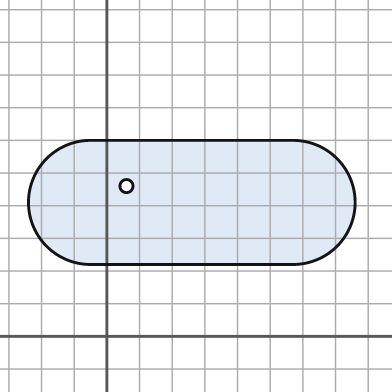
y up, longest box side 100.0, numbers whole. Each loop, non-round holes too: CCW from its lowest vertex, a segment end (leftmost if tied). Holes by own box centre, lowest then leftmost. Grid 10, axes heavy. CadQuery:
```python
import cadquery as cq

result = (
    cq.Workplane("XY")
    .moveTo(-5.0, 22.0)
    .lineTo(57.0, 22.0)
    .threePointArc((76.0, 41.0), (57.0, 60.0))
    .lineTo(-5.0, 60.0)
    .threePointArc((-24.0, 41.0), (-5.0, 22.0))
    .close()
    .moveTo(6.0, 46.0)
    .circle(2.0)
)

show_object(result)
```